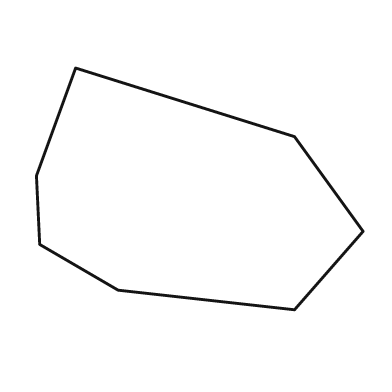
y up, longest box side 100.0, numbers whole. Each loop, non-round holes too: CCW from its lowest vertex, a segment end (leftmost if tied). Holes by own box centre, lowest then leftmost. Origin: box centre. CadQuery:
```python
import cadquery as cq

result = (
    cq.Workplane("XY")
    .moveTo(29.0, -37.0)
    .lineTo(50.0, -13.0)
    .lineTo(29.0, 16.0)
    .lineTo(-38.0, 37.0)
    .lineTo(-50.0, 4.0)
    .lineTo(-49.0, -17.0)
    .lineTo(-25.0, -31.0)
    .close()
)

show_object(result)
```